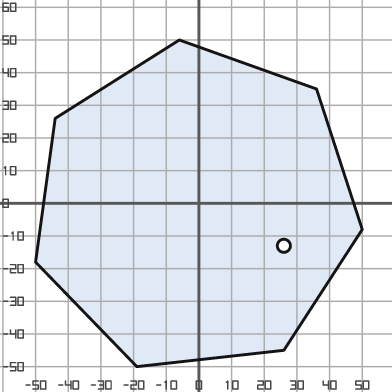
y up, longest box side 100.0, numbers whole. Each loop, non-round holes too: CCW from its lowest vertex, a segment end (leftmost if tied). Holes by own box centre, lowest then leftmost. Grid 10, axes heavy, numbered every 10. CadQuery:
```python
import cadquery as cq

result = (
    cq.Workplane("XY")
    .moveTo(-19.0, -50.0)
    .lineTo(26.0, -45.0)
    .lineTo(50.0, -8.0)
    .lineTo(36.0, 35.0)
    .lineTo(-6.0, 50.0)
    .lineTo(-44.0, 26.0)
    .lineTo(-50.0, -18.0)
    .close()
    .moveTo(26.0, -13.0)
    .circle(2.0)
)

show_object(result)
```